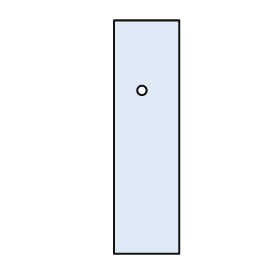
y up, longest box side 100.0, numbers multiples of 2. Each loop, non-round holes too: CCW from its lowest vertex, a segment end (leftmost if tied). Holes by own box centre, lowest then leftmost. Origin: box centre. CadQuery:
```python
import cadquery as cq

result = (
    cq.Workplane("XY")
    .moveTo(-14.0, -50.0)
    .lineTo(14.0, -50.0)
    .lineTo(14.0, 50.0)
    .lineTo(-14.0, 50.0)
    .close()
    .moveTo(-2.0, 20.0)
    .circle(2.0)
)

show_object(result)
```